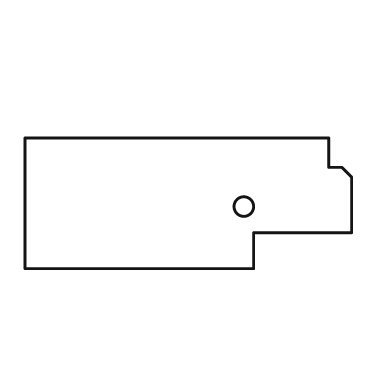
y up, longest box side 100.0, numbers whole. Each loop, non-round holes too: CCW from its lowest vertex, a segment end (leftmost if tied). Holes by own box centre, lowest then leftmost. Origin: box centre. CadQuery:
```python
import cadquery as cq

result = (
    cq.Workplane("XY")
    .moveTo(-50.0, -20.0)
    .lineTo(20.0, -20.0)
    .lineTo(20.0, -9.0)
    .lineTo(50.0, -9.0)
    .lineTo(50.0, 8.0)
    .lineTo(47.0, 11.0)
    .lineTo(43.0, 11.0)
    .lineTo(43.0, 20.0)
    .lineTo(-50.0, 20.0)
    .close()
    .moveTo(17.0, -1.0)
    .circle(3.0)
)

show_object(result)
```